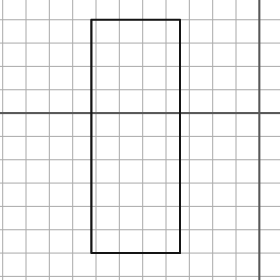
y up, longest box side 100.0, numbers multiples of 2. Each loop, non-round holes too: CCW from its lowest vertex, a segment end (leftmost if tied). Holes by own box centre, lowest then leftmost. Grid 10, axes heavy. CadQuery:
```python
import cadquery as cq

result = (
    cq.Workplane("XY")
    .moveTo(-72.0, -60.0)
    .lineTo(-34.0, -60.0)
    .lineTo(-34.0, 40.0)
    .lineTo(-72.0, 40.0)
    .close()
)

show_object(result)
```